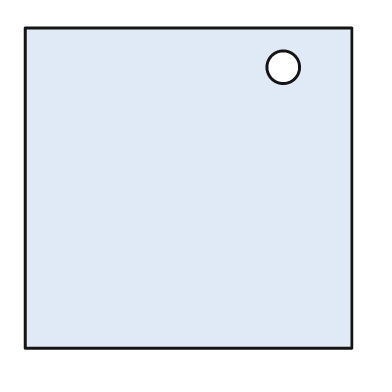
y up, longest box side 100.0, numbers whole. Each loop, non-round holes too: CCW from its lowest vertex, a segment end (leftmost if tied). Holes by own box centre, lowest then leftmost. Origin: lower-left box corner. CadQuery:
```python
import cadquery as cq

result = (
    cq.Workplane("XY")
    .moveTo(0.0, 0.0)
    .lineTo(100.0, 0.0)
    .lineTo(100.0, 98.0)
    .lineTo(0.0, 98.0)
    .close()
    .moveTo(79.0, 86.0)
    .circle(5.0)
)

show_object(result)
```